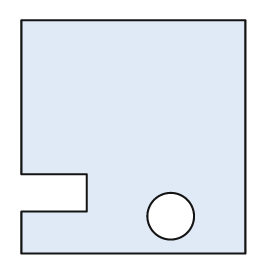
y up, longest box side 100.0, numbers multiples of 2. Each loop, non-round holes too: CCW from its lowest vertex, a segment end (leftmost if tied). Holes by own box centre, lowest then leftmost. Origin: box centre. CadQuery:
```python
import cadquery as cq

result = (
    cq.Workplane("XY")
    .moveTo(-48.0, -50.0)
    .lineTo(48.0, -50.0)
    .lineTo(48.0, 50.0)
    .lineTo(-48.0, 50.0)
    .lineTo(-48.0, -16.0)
    .lineTo(-20.0, -16.0)
    .lineTo(-20.0, -32.0)
    .lineTo(-48.0, -32.0)
    .close()
    .moveTo(16.0, -34.0)
    .circle(10.0)
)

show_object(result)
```